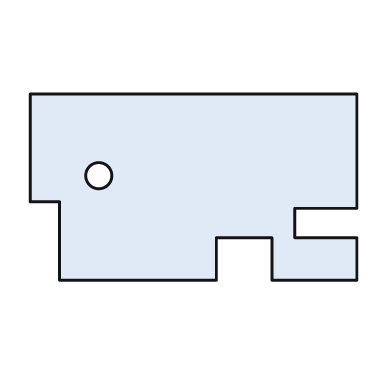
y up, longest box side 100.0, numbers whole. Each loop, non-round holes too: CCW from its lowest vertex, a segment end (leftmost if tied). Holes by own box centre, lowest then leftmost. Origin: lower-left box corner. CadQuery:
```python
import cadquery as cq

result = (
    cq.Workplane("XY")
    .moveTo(9.0, 0.0)
    .lineTo(57.0, 0.0)
    .lineTo(57.0, 13.0)
    .lineTo(74.0, 13.0)
    .lineTo(74.0, 0.0)
    .lineTo(100.0, 0.0)
    .lineTo(100.0, 13.0)
    .lineTo(81.0, 13.0)
    .lineTo(81.0, 22.0)
    .lineTo(100.0, 22.0)
    .lineTo(100.0, 57.0)
    .lineTo(0.0, 57.0)
    .lineTo(0.0, 24.0)
    .lineTo(9.0, 24.0)
    .close()
    .moveTo(21.0, 32.0)
    .circle(4.0)
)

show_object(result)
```